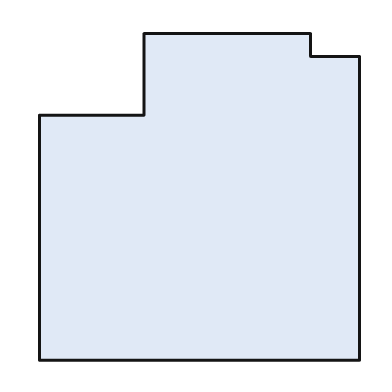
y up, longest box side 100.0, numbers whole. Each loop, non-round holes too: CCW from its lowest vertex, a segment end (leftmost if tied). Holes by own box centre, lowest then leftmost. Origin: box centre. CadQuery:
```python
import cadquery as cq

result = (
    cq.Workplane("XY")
    .moveTo(-49.0, -50.0)
    .lineTo(49.0, -50.0)
    .lineTo(49.0, 43.0)
    .lineTo(34.0, 43.0)
    .lineTo(34.0, 50.0)
    .lineTo(-17.0, 50.0)
    .lineTo(-17.0, 25.0)
    .lineTo(-49.0, 25.0)
    .close()
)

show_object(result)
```